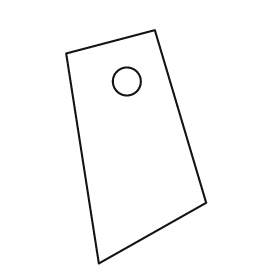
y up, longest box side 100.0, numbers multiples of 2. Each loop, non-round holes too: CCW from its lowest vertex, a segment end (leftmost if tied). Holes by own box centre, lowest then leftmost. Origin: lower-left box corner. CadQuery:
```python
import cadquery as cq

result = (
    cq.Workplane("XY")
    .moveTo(14.0, 0.0)
    .lineTo(60.0, 26.0)
    .lineTo(38.0, 100.0)
    .lineTo(0.0, 90.0)
    .close()
    .moveTo(26.0, 78.0)
    .circle(6.0)
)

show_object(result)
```